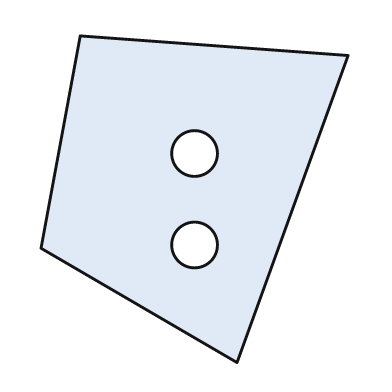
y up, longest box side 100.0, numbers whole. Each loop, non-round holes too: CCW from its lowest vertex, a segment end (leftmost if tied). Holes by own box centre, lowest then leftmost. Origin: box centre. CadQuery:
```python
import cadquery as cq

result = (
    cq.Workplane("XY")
    .moveTo(13.0, -50.0)
    .lineTo(47.0, 44.0)
    .lineTo(-35.0, 50.0)
    .lineTo(-47.0, -15.0)
    .close()
    .moveTo(0.0, -14.0)
    .circle(7.0)
    .moveTo(0.0, 14.0)
    .circle(7.0)
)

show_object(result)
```